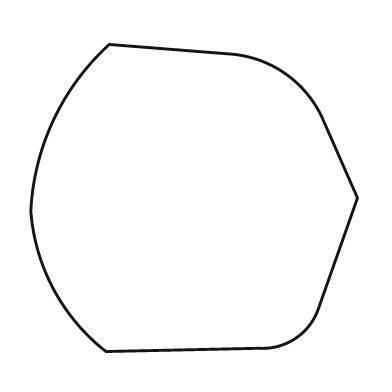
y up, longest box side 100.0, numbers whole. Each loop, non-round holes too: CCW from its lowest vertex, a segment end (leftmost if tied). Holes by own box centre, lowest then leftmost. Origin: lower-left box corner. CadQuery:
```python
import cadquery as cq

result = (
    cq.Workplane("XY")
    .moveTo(23.0, 0.0)
    .lineTo(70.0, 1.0)
    .threePointArc((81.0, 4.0), (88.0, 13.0))
    .lineTo(100.0, 47.0)
    .lineTo(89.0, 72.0)
    .threePointArc((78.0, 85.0), (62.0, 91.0))
    .lineTo(24.0, 94.0)
    .threePointArc((7.0, 71.0), (0.0, 43.0))
    .threePointArc((7.0, 19.0), (23.0, 0.0))
    .close()
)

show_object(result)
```